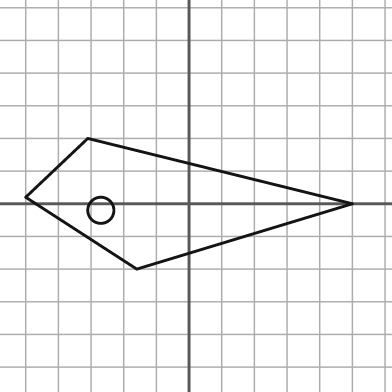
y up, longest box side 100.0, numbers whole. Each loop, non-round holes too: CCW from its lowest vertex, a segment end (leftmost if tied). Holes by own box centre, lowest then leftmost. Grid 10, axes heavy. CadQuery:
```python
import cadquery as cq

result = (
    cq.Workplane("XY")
    .moveTo(-16.0, -20.0)
    .lineTo(50.0, 0.0)
    .lineTo(-31.0, 20.0)
    .lineTo(-50.0, 2.0)
    .close()
    .moveTo(-27.0, -2.0)
    .circle(4.0)
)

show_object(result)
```